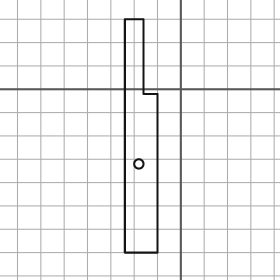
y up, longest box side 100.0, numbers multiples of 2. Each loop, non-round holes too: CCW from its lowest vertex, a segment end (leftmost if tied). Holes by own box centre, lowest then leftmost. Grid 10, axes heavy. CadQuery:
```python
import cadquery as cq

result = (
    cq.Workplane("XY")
    .moveTo(-24.0, -70.0)
    .lineTo(-10.0, -70.0)
    .lineTo(-10.0, -2.0)
    .lineTo(-16.0, -2.0)
    .lineTo(-16.0, 30.0)
    .lineTo(-24.0, 30.0)
    .close()
    .moveTo(-18.0, -32.0)
    .circle(2.0)
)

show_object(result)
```